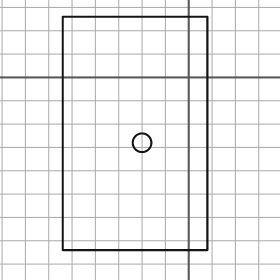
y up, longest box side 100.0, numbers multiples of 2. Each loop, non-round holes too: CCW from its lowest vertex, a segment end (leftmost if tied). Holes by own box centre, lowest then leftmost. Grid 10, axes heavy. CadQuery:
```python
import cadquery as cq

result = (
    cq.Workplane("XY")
    .moveTo(-54.0, -74.0)
    .lineTo(8.0, -74.0)
    .lineTo(8.0, 26.0)
    .lineTo(-54.0, 26.0)
    .close()
    .moveTo(-20.0, -28.0)
    .circle(4.0)
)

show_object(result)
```